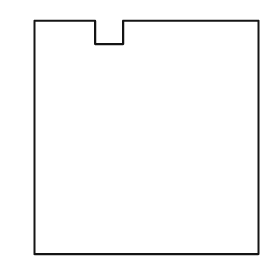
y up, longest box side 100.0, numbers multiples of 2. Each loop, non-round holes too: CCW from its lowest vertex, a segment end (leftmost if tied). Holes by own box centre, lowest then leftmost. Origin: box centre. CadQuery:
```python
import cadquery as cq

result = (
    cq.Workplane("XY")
    .moveTo(-48.0, -50.0)
    .lineTo(48.0, -50.0)
    .lineTo(48.0, 50.0)
    .lineTo(-10.0, 50.0)
    .lineTo(-10.0, 40.0)
    .lineTo(-22.0, 40.0)
    .lineTo(-22.0, 50.0)
    .lineTo(-48.0, 50.0)
    .close()
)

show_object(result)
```